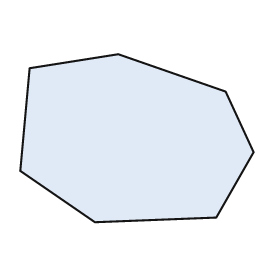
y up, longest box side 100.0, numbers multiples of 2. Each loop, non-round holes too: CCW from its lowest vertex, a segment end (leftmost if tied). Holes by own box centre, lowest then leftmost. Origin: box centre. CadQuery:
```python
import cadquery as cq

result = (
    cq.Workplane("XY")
    .moveTo(-18.0, -36.0)
    .lineTo(34.0, -34.0)
    .lineTo(50.0, -6.0)
    .lineTo(38.0, 20.0)
    .lineTo(-8.0, 36.0)
    .lineTo(-46.0, 30.0)
    .lineTo(-50.0, -14.0)
    .close()
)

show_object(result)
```